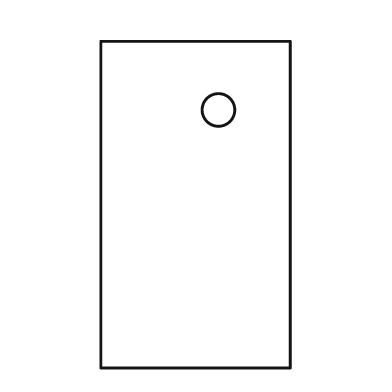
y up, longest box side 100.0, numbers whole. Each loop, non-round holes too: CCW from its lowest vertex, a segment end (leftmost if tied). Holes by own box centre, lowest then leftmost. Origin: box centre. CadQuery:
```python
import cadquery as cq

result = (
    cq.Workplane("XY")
    .moveTo(-29.0, -50.0)
    .lineTo(29.0, -50.0)
    .lineTo(29.0, 50.0)
    .lineTo(-29.0, 50.0)
    .close()
    .moveTo(7.0, 29.0)
    .circle(5.0)
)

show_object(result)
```